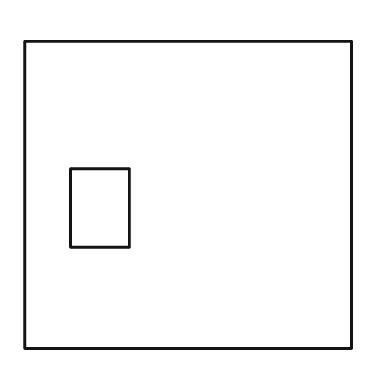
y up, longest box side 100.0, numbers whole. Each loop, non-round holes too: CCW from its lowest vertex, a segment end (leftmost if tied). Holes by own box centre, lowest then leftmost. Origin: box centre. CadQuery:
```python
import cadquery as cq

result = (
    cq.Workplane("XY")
    .moveTo(-50.0, -47.0)
    .lineTo(50.0, -47.0)
    .lineTo(50.0, 47.0)
    .lineTo(-50.0, 47.0)
    .close()
    .moveTo(-36.0, -16.0)
    .lineTo(-18.0, -16.0)
    .lineTo(-18.0, 8.0)
    .lineTo(-36.0, 8.0)
    .close()
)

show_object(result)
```